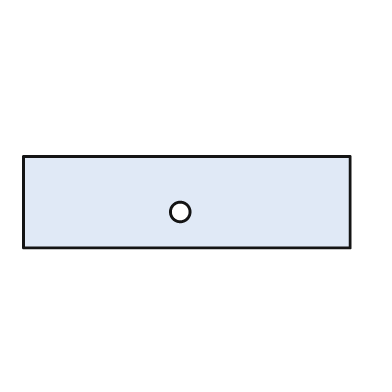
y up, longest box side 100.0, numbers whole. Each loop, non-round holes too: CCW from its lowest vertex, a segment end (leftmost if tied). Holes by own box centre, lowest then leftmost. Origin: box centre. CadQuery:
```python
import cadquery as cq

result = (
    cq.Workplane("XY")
    .moveTo(-50.0, -14.0)
    .lineTo(50.0, -14.0)
    .lineTo(50.0, 14.0)
    .lineTo(-50.0, 14.0)
    .close()
    .moveTo(-2.0, -3.0)
    .circle(3.0)
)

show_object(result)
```